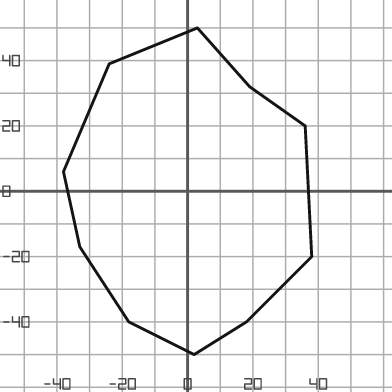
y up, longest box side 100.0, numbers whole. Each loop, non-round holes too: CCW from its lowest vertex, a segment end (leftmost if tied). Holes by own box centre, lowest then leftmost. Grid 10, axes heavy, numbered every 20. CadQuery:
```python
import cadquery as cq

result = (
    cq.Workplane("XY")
    .moveTo(2.0, -50.0)
    .lineTo(18.0, -40.0)
    .lineTo(38.0, -20.0)
    .lineTo(36.0, 20.0)
    .lineTo(19.0, 32.0)
    .lineTo(3.0, 50.0)
    .lineTo(-24.0, 39.0)
    .lineTo(-38.0, 6.0)
    .lineTo(-33.0, -17.0)
    .lineTo(-18.0, -40.0)
    .close()
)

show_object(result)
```